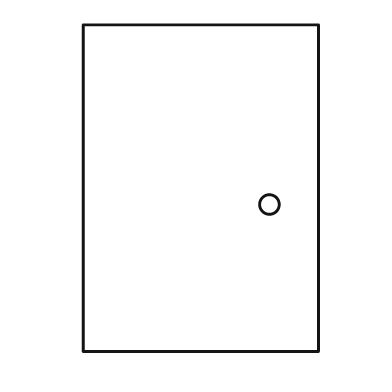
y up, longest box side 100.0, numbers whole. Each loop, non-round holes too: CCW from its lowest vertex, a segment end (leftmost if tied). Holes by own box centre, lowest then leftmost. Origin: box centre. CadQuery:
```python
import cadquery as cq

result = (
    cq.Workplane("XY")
    .moveTo(-36.0, -50.0)
    .lineTo(36.0, -50.0)
    .lineTo(36.0, 50.0)
    .lineTo(-36.0, 50.0)
    .close()
    .moveTo(21.0, -5.0)
    .circle(3.0)
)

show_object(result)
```